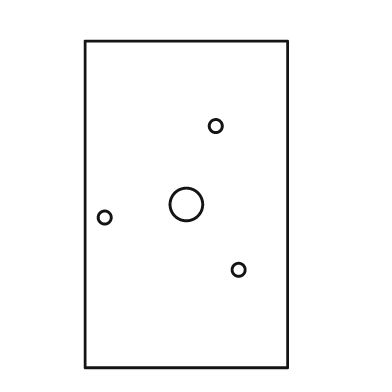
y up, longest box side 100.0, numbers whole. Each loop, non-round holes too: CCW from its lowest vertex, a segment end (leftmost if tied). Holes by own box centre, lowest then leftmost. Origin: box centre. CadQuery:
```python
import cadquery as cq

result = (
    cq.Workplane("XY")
    .moveTo(-31.0, -50.0)
    .lineTo(31.0, -50.0)
    .lineTo(31.0, 50.0)
    .lineTo(-31.0, 50.0)
    .close()
    .moveTo(16.0, -20.0)
    .circle(2.0)
    .moveTo(-25.0, -4.0)
    .circle(2.0)
    .moveTo(0.0, 0.0)
    .circle(5.0)
    .moveTo(9.0, 24.0)
    .circle(2.0)
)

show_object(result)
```